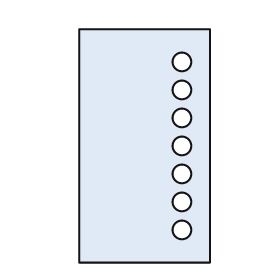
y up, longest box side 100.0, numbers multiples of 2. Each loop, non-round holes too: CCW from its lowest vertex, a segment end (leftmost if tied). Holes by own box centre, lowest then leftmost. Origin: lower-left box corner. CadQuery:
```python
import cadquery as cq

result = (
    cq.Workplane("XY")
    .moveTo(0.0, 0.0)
    .lineTo(56.0, 0.0)
    .lineTo(56.0, 100.0)
    .lineTo(0.0, 100.0)
    .close()
    .moveTo(44.0, 14.0)
    .circle(4.0)
    .moveTo(44.0, 26.0)
    .circle(4.0)
    .moveTo(44.0, 38.0)
    .circle(4.0)
    .moveTo(44.0, 50.0)
    .circle(4.0)
    .moveTo(44.0, 62.0)
    .circle(4.0)
    .moveTo(44.0, 74.0)
    .circle(4.0)
    .moveTo(44.0, 86.0)
    .circle(4.0)
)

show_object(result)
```